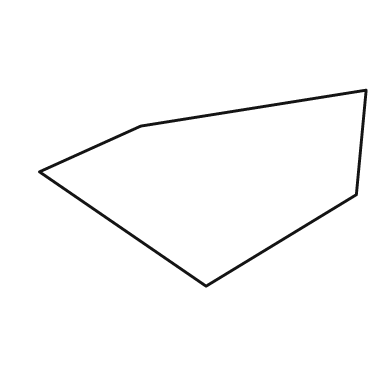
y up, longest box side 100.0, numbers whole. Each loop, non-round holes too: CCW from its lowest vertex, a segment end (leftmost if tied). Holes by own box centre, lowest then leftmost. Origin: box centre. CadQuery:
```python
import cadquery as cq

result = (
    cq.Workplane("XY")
    .moveTo(1.0, -30.0)
    .lineTo(47.0, -2.0)
    .lineTo(50.0, 30.0)
    .lineTo(-19.0, 19.0)
    .lineTo(-50.0, 5.0)
    .close()
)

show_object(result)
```